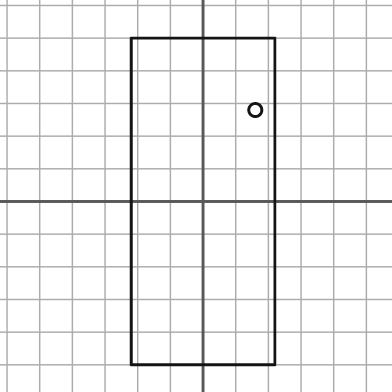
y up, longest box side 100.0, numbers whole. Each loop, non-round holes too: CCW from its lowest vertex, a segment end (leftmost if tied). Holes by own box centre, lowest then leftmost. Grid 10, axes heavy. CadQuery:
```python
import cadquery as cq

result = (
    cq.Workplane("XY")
    .moveTo(-22.0, -50.0)
    .lineTo(22.0, -50.0)
    .lineTo(22.0, 50.0)
    .lineTo(-22.0, 50.0)
    .close()
    .moveTo(16.0, 28.0)
    .circle(2.0)
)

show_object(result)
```